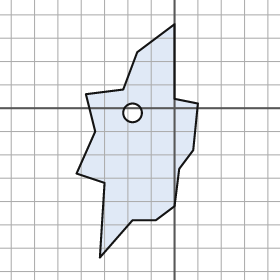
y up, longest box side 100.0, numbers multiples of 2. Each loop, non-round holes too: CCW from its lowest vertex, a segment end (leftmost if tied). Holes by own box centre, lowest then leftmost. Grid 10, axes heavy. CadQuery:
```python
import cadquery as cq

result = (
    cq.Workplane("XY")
    .moveTo(-32.0, -64.0)
    .lineTo(-18.0, -48.0)
    .lineTo(-8.0, -48.0)
    .lineTo(0.0, -42.0)
    .lineTo(2.0, -26.0)
    .lineTo(8.0, -18.0)
    .lineTo(10.0, 2.0)
    .lineTo(0.0, 4.0)
    .lineTo(0.0, 36.0)
    .lineTo(-16.0, 24.0)
    .lineTo(-22.0, 8.0)
    .lineTo(-38.0, 6.0)
    .lineTo(-34.0, -10.0)
    .lineTo(-42.0, -28.0)
    .lineTo(-30.0, -32.0)
    .close()
    .moveTo(-18.0, -2.0)
    .circle(4.0)
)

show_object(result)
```